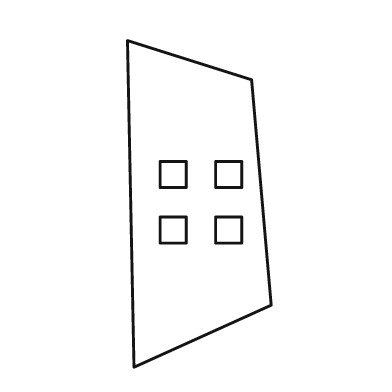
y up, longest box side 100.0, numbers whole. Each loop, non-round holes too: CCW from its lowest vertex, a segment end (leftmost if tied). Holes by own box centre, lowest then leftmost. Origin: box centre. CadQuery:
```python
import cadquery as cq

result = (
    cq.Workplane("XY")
    .moveTo(-20.0, -50.0)
    .lineTo(22.0, -31.0)
    .lineTo(16.0, 38.0)
    .lineTo(-22.0, 50.0)
    .close()
    .moveTo(-12.0, -12.0)
    .lineTo(-4.0, -12.0)
    .lineTo(-4.0, -4.0)
    .lineTo(-12.0, -4.0)
    .close()
    .moveTo(5.0, -12.0)
    .lineTo(13.0, -12.0)
    .lineTo(13.0, -4.0)
    .lineTo(5.0, -4.0)
    .close()
    .moveTo(-12.0, 5.0)
    .lineTo(-4.0, 5.0)
    .lineTo(-4.0, 13.0)
    .lineTo(-12.0, 13.0)
    .close()
    .moveTo(5.0, 5.0)
    .lineTo(13.0, 5.0)
    .lineTo(13.0, 13.0)
    .lineTo(5.0, 13.0)
    .close()
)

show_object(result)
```